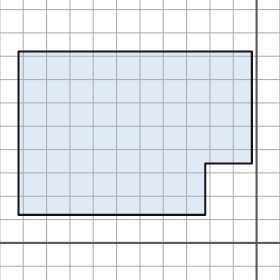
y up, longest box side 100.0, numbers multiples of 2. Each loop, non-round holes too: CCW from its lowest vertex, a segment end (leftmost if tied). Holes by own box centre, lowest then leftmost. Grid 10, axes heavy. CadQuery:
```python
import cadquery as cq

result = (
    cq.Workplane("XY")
    .moveTo(-102.0, 12.0)
    .lineTo(-22.0, 12.0)
    .lineTo(-22.0, 34.0)
    .lineTo(-2.0, 34.0)
    .lineTo(-2.0, 82.0)
    .lineTo(-102.0, 82.0)
    .close()
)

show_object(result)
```